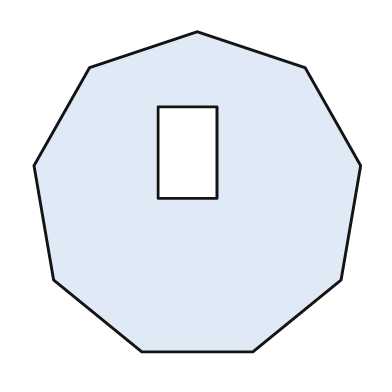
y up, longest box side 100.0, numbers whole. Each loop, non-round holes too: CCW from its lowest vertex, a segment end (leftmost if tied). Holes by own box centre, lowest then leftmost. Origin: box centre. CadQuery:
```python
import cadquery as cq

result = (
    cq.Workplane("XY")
    .moveTo(-17.0, -49.0)
    .lineTo(17.0, -49.0)
    .lineTo(44.0, -27.0)
    .lineTo(50.0, 8.0)
    .lineTo(33.0, 38.0)
    .lineTo(0.0, 49.0)
    .lineTo(-33.0, 38.0)
    .lineTo(-50.0, 8.0)
    .lineTo(-44.0, -27.0)
    .close()
    .moveTo(-12.0, -2.0)
    .lineTo(6.0, -2.0)
    .lineTo(6.0, 26.0)
    .lineTo(-12.0, 26.0)
    .close()
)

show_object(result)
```